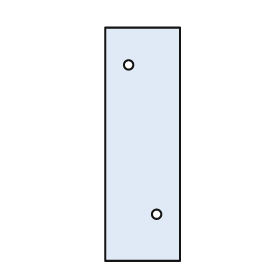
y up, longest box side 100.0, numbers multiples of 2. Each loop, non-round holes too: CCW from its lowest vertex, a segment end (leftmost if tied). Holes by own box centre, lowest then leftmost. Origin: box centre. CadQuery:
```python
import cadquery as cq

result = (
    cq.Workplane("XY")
    .moveTo(-16.0, -50.0)
    .lineTo(16.0, -50.0)
    .lineTo(16.0, 50.0)
    .lineTo(-16.0, 50.0)
    .close()
    .moveTo(6.0, -30.0)
    .circle(2.0)
    .moveTo(-6.0, 34.0)
    .circle(2.0)
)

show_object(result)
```